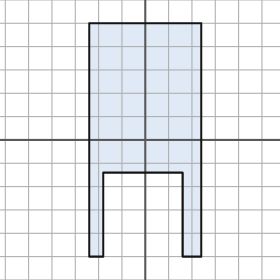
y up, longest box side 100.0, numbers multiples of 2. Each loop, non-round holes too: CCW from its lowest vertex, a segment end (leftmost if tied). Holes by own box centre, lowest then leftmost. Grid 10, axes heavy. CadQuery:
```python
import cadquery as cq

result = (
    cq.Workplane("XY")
    .moveTo(-24.0, -50.0)
    .lineTo(-18.0, -50.0)
    .lineTo(-18.0, -14.0)
    .lineTo(16.0, -14.0)
    .lineTo(16.0, -50.0)
    .lineTo(24.0, -50.0)
    .lineTo(24.0, 50.0)
    .lineTo(-24.0, 50.0)
    .close()
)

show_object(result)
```